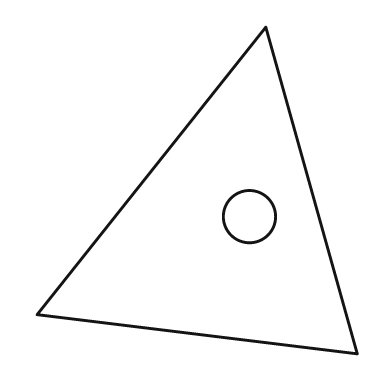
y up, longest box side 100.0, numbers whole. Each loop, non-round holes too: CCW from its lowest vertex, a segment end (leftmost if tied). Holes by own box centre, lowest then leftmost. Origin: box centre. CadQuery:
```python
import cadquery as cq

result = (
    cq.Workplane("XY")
    .moveTo(49.0, -50.0)
    .lineTo(21.0, 50.0)
    .lineTo(-49.0, -38.0)
    .close()
    .moveTo(16.0, -8.0)
    .circle(8.0)
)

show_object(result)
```